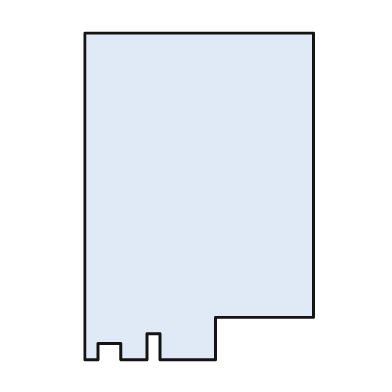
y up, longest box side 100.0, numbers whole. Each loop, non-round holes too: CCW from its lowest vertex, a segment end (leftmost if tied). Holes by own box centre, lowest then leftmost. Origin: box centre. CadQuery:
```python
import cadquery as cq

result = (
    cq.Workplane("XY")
    .moveTo(-35.0, -50.0)
    .lineTo(-31.0, -50.0)
    .lineTo(-31.0, -45.0)
    .lineTo(-24.0, -45.0)
    .lineTo(-24.0, -50.0)
    .lineTo(-16.0, -50.0)
    .lineTo(-16.0, -42.0)
    .lineTo(-12.0, -42.0)
    .lineTo(-12.0, -50.0)
    .lineTo(5.0, -50.0)
    .lineTo(5.0, -37.0)
    .lineTo(35.0, -37.0)
    .lineTo(35.0, 50.0)
    .lineTo(-35.0, 50.0)
    .close()
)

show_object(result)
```